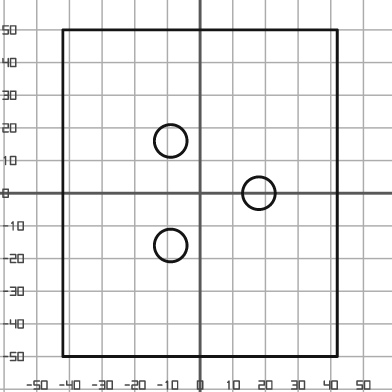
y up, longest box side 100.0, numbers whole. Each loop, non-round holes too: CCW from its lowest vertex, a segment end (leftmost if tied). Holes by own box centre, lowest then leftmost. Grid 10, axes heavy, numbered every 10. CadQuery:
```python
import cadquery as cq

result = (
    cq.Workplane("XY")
    .moveTo(-42.0, -50.0)
    .lineTo(42.0, -50.0)
    .lineTo(42.0, 50.0)
    .lineTo(-42.0, 50.0)
    .close()
    .moveTo(-9.0, -16.0)
    .circle(5.0)
    .moveTo(18.0, 0.0)
    .circle(5.0)
    .moveTo(-9.0, 16.0)
    .circle(5.0)
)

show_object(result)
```